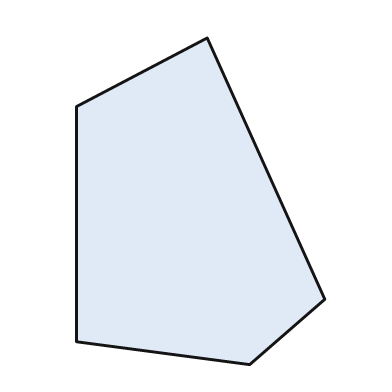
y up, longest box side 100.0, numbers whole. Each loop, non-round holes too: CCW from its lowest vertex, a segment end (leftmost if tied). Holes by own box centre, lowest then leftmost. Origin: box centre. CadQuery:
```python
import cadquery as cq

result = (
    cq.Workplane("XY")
    .moveTo(15.0, -50.0)
    .lineTo(38.0, -30.0)
    .lineTo(2.0, 50.0)
    .lineTo(-38.0, 29.0)
    .lineTo(-38.0, -43.0)
    .close()
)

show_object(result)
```